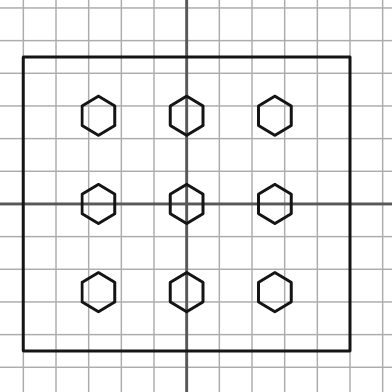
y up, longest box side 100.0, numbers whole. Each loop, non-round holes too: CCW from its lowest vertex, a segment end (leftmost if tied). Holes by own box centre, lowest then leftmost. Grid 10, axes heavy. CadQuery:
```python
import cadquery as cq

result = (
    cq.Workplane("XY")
    .moveTo(-50.0, -45.0)
    .lineTo(50.0, -45.0)
    .lineTo(50.0, 45.0)
    .lineTo(-50.0, 45.0)
    .close()
    .moveTo(-27.0, -33.0)
    .lineTo(-22.0, -30.0)
    .lineTo(-22.0, -24.0)
    .lineTo(-27.0, -21.0)
    .lineTo(-32.0, -24.0)
    .lineTo(-32.0, -30.0)
    .close()
    .moveTo(0.0, -33.0)
    .lineTo(5.0, -30.0)
    .lineTo(5.0, -24.0)
    .lineTo(0.0, -21.0)
    .lineTo(-5.0, -24.0)
    .lineTo(-5.0, -30.0)
    .close()
    .moveTo(27.0, -33.0)
    .lineTo(32.0, -30.0)
    .lineTo(32.0, -24.0)
    .lineTo(27.0, -21.0)
    .lineTo(22.0, -24.0)
    .lineTo(22.0, -30.0)
    .close()
    .moveTo(-27.0, -6.0)
    .lineTo(-22.0, -3.0)
    .lineTo(-22.0, 3.0)
    .lineTo(-27.0, 6.0)
    .lineTo(-32.0, 3.0)
    .lineTo(-32.0, -3.0)
    .close()
    .moveTo(0.0, -6.0)
    .lineTo(5.0, -3.0)
    .lineTo(5.0, 3.0)
    .lineTo(0.0, 6.0)
    .lineTo(-5.0, 3.0)
    .lineTo(-5.0, -3.0)
    .close()
    .moveTo(27.0, -6.0)
    .lineTo(32.0, -3.0)
    .lineTo(32.0, 3.0)
    .lineTo(27.0, 6.0)
    .lineTo(22.0, 3.0)
    .lineTo(22.0, -3.0)
    .close()
    .moveTo(-27.0, 21.0)
    .lineTo(-22.0, 24.0)
    .lineTo(-22.0, 30.0)
    .lineTo(-27.0, 33.0)
    .lineTo(-32.0, 30.0)
    .lineTo(-32.0, 24.0)
    .close()
    .moveTo(0.0, 21.0)
    .lineTo(5.0, 24.0)
    .lineTo(5.0, 30.0)
    .lineTo(0.0, 33.0)
    .lineTo(-5.0, 30.0)
    .lineTo(-5.0, 24.0)
    .close()
    .moveTo(27.0, 21.0)
    .lineTo(32.0, 24.0)
    .lineTo(32.0, 30.0)
    .lineTo(27.0, 33.0)
    .lineTo(22.0, 30.0)
    .lineTo(22.0, 24.0)
    .close()
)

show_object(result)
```